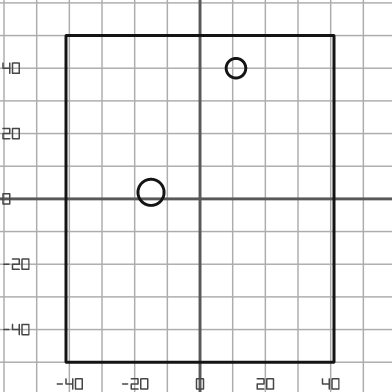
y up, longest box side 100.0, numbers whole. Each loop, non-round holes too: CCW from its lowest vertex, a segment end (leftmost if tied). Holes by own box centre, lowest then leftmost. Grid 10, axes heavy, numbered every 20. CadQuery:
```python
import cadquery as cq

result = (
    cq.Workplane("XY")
    .moveTo(-41.0, -50.0)
    .lineTo(41.0, -50.0)
    .lineTo(41.0, 50.0)
    .lineTo(-41.0, 50.0)
    .close()
    .moveTo(-15.0, 2.0)
    .circle(4.0)
    .moveTo(11.0, 40.0)
    .circle(3.0)
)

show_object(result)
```